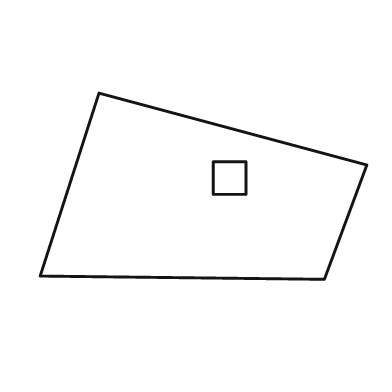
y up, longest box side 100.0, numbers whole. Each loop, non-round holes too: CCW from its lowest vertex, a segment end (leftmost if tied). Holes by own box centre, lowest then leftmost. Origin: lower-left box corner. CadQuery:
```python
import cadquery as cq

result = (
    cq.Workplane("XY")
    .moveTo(87.0, 0.0)
    .lineTo(100.0, 35.0)
    .lineTo(18.0, 57.0)
    .lineTo(0.0, 1.0)
    .close()
    .moveTo(53.0, 26.0)
    .lineTo(63.0, 26.0)
    .lineTo(63.0, 36.0)
    .lineTo(53.0, 36.0)
    .close()
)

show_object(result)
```